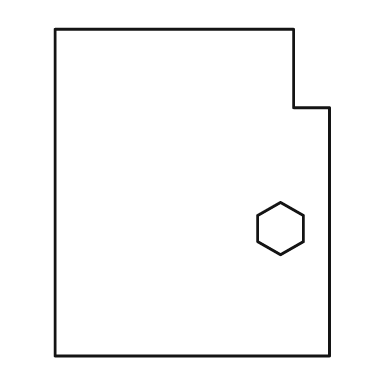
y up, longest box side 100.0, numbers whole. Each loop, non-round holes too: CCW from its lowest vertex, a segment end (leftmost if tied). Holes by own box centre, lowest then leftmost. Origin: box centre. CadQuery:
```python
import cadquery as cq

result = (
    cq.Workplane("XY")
    .moveTo(-42.0, -50.0)
    .lineTo(42.0, -50.0)
    .lineTo(42.0, 26.0)
    .lineTo(31.0, 26.0)
    .lineTo(31.0, 50.0)
    .lineTo(-42.0, 50.0)
    .close()
    .moveTo(27.0, -19.0)
    .lineTo(34.0, -15.0)
    .lineTo(34.0, -7.0)
    .lineTo(27.0, -3.0)
    .lineTo(20.0, -7.0)
    .lineTo(20.0, -15.0)
    .close()
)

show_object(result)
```